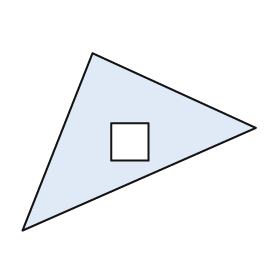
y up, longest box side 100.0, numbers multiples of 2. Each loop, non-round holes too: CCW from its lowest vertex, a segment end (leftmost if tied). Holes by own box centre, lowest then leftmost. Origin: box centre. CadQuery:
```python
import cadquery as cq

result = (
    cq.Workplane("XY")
    .moveTo(-50.0, -38.0)
    .lineTo(50.0, 6.0)
    .lineTo(-20.0, 38.0)
    .close()
    .moveTo(-12.0, -8.0)
    .lineTo(4.0, -8.0)
    .lineTo(4.0, 8.0)
    .lineTo(-12.0, 8.0)
    .close()
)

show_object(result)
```